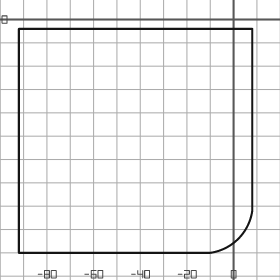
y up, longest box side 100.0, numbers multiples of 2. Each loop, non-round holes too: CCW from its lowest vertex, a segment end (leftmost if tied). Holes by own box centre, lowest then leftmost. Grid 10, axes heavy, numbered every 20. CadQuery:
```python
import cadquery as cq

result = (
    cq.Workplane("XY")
    .moveTo(-92.0, -100.0)
    .lineTo(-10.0, -100.0)
    .threePointArc((2.0, -94.0), (8.0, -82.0))
    .lineTo(8.0, -4.0)
    .lineTo(-92.0, -4.0)
    .close()
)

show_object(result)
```